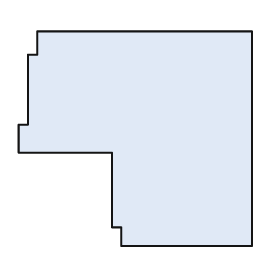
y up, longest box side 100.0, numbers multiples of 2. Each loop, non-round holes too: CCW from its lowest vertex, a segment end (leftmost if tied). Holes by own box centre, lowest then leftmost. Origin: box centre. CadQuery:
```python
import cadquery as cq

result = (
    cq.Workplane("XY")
    .moveTo(-6.0, -46.0)
    .lineTo(50.0, -46.0)
    .lineTo(50.0, 46.0)
    .lineTo(-42.0, 46.0)
    .lineTo(-42.0, 36.0)
    .lineTo(-46.0, 36.0)
    .lineTo(-46.0, 6.0)
    .lineTo(-50.0, 6.0)
    .lineTo(-50.0, -6.0)
    .lineTo(-10.0, -6.0)
    .lineTo(-10.0, -38.0)
    .lineTo(-6.0, -38.0)
    .close()
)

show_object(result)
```